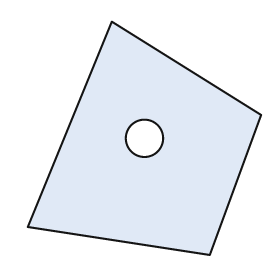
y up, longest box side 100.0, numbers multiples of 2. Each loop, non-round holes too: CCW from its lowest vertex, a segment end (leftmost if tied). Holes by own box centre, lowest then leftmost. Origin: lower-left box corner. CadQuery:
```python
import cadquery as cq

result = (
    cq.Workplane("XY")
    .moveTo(78.0, 0.0)
    .lineTo(100.0, 60.0)
    .lineTo(36.0, 100.0)
    .lineTo(0.0, 12.0)
    .close()
    .moveTo(50.0, 50.0)
    .circle(8.0)
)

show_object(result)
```